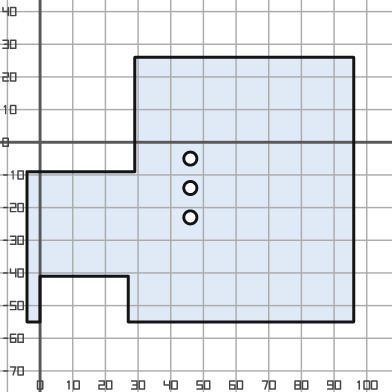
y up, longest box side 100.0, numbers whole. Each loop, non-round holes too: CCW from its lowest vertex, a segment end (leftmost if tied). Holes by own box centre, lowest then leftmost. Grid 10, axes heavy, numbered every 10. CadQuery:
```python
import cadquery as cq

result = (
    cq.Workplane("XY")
    .moveTo(-4.0, -55.0)
    .lineTo(0.0, -55.0)
    .lineTo(0.0, -41.0)
    .lineTo(27.0, -41.0)
    .lineTo(27.0, -55.0)
    .lineTo(96.0, -55.0)
    .lineTo(96.0, 26.0)
    .lineTo(29.0, 26.0)
    .lineTo(29.0, -9.0)
    .lineTo(-4.0, -9.0)
    .close()
    .moveTo(46.0, -23.0)
    .circle(2.0)
    .moveTo(46.0, -14.0)
    .circle(2.0)
    .moveTo(46.0, -5.0)
    .circle(2.0)
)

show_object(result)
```